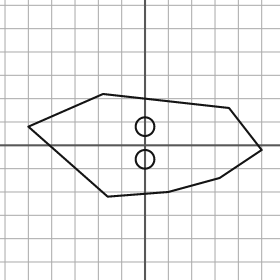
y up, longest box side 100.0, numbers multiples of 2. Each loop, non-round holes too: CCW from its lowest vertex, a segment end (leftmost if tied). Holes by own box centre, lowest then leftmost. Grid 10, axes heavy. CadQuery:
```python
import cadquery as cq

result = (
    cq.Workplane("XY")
    .moveTo(-16.0, -22.0)
    .lineTo(10.0, -20.0)
    .lineTo(32.0, -14.0)
    .lineTo(50.0, -2.0)
    .lineTo(36.0, 16.0)
    .lineTo(-18.0, 22.0)
    .lineTo(-50.0, 8.0)
    .close()
    .moveTo(0.0, -6.0)
    .circle(4.0)
    .moveTo(0.0, 8.0)
    .circle(4.0)
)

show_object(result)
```